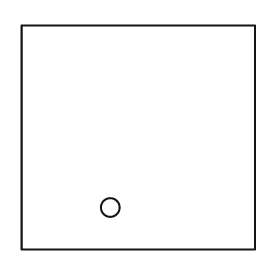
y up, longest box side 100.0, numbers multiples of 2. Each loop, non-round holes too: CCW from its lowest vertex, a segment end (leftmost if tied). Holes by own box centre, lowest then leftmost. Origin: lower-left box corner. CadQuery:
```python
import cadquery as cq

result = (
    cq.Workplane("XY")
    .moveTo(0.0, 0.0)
    .lineTo(100.0, 0.0)
    .lineTo(100.0, 96.0)
    .lineTo(0.0, 96.0)
    .close()
    .moveTo(38.0, 18.0)
    .circle(4.0)
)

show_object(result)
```